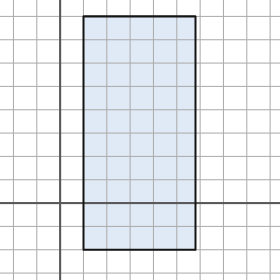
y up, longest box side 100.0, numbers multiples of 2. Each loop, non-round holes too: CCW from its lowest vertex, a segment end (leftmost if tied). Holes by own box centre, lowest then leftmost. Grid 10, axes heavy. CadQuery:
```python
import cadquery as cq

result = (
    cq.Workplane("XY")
    .moveTo(10.0, -20.0)
    .lineTo(58.0, -20.0)
    .lineTo(58.0, 80.0)
    .lineTo(10.0, 80.0)
    .close()
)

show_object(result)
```